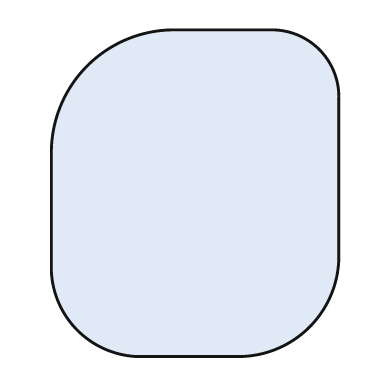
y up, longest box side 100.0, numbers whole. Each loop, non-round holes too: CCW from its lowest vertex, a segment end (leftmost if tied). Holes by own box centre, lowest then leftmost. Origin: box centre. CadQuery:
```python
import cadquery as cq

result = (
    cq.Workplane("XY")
    .moveTo(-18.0, -50.0)
    .lineTo(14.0, -50.0)
    .threePointArc((35.0, -41.0), (44.0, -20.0))
    .lineTo(44.0, 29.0)
    .threePointArc((38.0, 44.0), (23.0, 50.0))
    .lineTo(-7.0, 50.0)
    .threePointArc((-33.0, 39.0), (-44.0, 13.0))
    .lineTo(-44.0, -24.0)
    .threePointArc((-36.0, -42.0), (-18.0, -50.0))
    .close()
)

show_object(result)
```